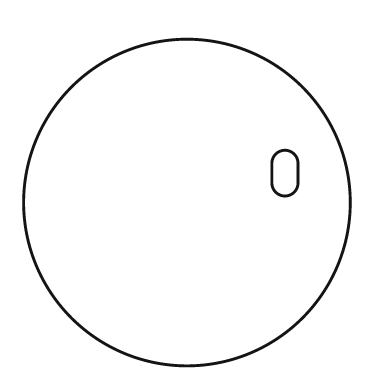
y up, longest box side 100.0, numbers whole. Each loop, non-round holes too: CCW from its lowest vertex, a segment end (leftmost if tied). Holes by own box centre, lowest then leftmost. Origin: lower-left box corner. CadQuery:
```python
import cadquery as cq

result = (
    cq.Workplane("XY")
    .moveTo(50.0, 50.0)
    .circle(50.0)
    .moveTo(76.0, 56.0)
    .threePointArc((80.0, 52.0), (84.0, 56.0))
    .lineTo(84.0, 62.0)
    .threePointArc((80.0, 66.0), (76.0, 62.0))
    .close()
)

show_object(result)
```